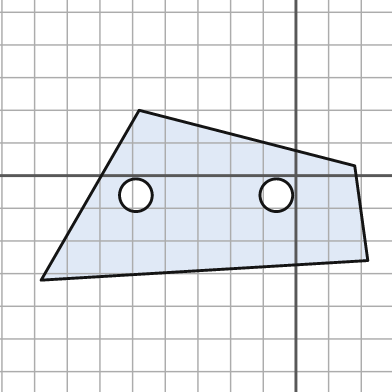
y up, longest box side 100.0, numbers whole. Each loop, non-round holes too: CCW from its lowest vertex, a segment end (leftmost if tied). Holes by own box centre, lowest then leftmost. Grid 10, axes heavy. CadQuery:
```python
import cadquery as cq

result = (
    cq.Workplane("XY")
    .moveTo(-78.0, -32.0)
    .lineTo(22.0, -26.0)
    .lineTo(18.0, 3.0)
    .lineTo(-48.0, 20.0)
    .close()
    .moveTo(-49.0, -6.0)
    .circle(5.0)
    .moveTo(-6.0, -6.0)
    .circle(5.0)
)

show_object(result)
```